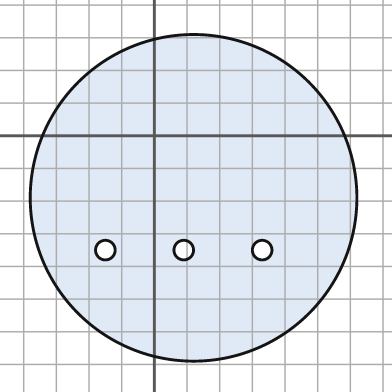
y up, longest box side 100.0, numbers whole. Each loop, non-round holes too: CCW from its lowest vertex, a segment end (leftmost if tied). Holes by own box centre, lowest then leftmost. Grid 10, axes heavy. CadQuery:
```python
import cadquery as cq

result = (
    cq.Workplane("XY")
    .moveTo(12.0, -19.0)
    .circle(50.0)
    .moveTo(-15.0, -35.0)
    .circle(3.0)
    .moveTo(9.0, -35.0)
    .circle(3.0)
    .moveTo(33.0, -35.0)
    .circle(3.0)
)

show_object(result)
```